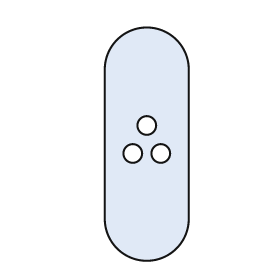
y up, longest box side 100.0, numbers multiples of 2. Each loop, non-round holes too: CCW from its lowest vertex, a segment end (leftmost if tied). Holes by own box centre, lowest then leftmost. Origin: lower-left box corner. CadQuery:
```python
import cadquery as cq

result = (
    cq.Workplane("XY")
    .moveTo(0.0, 18.0)
    .threePointArc((18.0, 0.0), (36.0, 18.0))
    .lineTo(36.0, 82.0)
    .threePointArc((18.0, 100.0), (0.0, 82.0))
    .close()
    .moveTo(12.0, 46.0)
    .circle(4.0)
    .moveTo(24.0, 46.0)
    .circle(4.0)
    .moveTo(18.0, 58.0)
    .circle(4.0)
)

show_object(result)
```